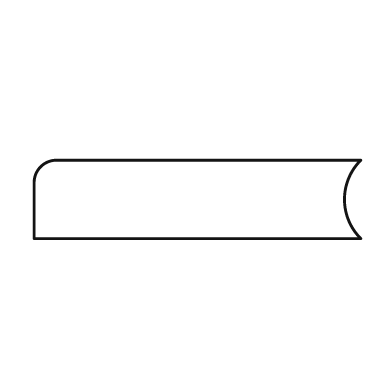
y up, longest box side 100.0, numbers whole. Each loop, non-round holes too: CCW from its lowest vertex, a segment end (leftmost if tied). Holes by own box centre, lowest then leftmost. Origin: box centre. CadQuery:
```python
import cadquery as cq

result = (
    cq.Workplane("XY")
    .moveTo(-50.0, -12.0)
    .lineTo(50.0, -12.0)
    .threePointArc((45.0, 0.0), (50.0, 12.0))
    .lineTo(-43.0, 12.0)
    .threePointArc((-48.0, 10.0), (-50.0, 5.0))
    .close()
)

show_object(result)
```